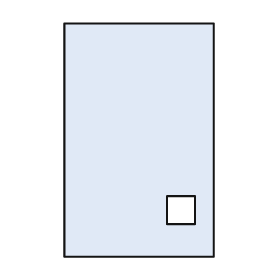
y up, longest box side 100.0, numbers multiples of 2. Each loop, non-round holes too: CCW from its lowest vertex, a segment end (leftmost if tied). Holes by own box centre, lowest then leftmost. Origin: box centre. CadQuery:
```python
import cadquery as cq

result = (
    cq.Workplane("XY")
    .moveTo(-32.0, -50.0)
    .lineTo(32.0, -50.0)
    .lineTo(32.0, 50.0)
    .lineTo(-32.0, 50.0)
    .close()
    .moveTo(12.0, -36.0)
    .lineTo(24.0, -36.0)
    .lineTo(24.0, -24.0)
    .lineTo(12.0, -24.0)
    .close()
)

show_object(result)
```